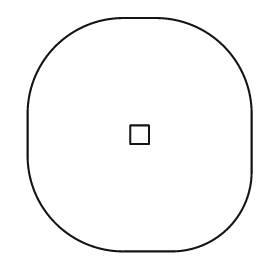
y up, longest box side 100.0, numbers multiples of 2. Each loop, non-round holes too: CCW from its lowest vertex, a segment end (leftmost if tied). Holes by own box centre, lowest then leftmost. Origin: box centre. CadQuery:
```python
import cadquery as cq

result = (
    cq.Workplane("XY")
    .moveTo(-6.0, -50.0)
    .lineTo(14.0, -50.0)
    .threePointArc((38.0, -40.0), (48.0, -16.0))
    .lineTo(48.0, 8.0)
    .threePointArc((36.0, 38.0), (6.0, 50.0))
    .lineTo(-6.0, 50.0)
    .threePointArc((-36.0, 38.0), (-48.0, 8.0))
    .lineTo(-48.0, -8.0)
    .threePointArc((-36.0, -38.0), (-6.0, -50.0))
    .close()
    .moveTo(-4.0, -4.0)
    .lineTo(4.0, -4.0)
    .lineTo(4.0, 4.0)
    .lineTo(-4.0, 4.0)
    .close()
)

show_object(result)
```